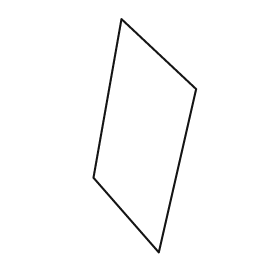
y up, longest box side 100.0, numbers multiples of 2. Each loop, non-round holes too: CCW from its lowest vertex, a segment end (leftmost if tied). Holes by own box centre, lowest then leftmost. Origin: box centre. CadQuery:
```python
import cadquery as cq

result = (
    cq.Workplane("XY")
    .moveTo(6.0, -50.0)
    .lineTo(22.0, 20.0)
    .lineTo(-10.0, 50.0)
    .lineTo(-22.0, -18.0)
    .close()
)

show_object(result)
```